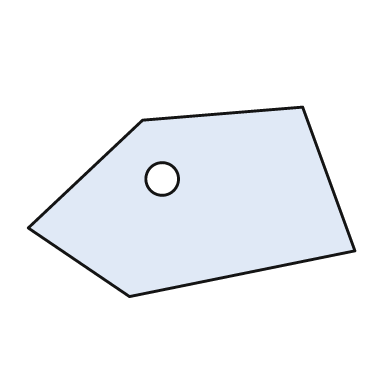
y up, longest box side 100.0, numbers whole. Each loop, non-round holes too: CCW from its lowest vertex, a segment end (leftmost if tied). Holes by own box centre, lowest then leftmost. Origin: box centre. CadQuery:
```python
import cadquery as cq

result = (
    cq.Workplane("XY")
    .moveTo(-19.0, -29.0)
    .lineTo(50.0, -15.0)
    .lineTo(34.0, 29.0)
    .lineTo(-15.0, 25.0)
    .lineTo(-50.0, -8.0)
    .close()
    .moveTo(-9.0, 7.0)
    .circle(5.0)
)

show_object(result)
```